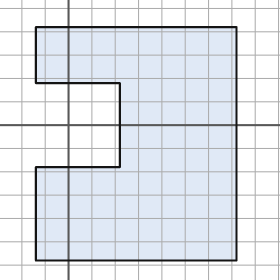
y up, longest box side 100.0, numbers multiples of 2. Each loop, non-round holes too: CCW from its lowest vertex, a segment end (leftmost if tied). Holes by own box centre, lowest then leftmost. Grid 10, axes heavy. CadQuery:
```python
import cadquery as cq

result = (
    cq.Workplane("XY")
    .moveTo(-14.0, -58.0)
    .lineTo(72.0, -58.0)
    .lineTo(72.0, 42.0)
    .lineTo(-14.0, 42.0)
    .lineTo(-14.0, 18.0)
    .lineTo(22.0, 18.0)
    .lineTo(22.0, -18.0)
    .lineTo(-14.0, -18.0)
    .close()
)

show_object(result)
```